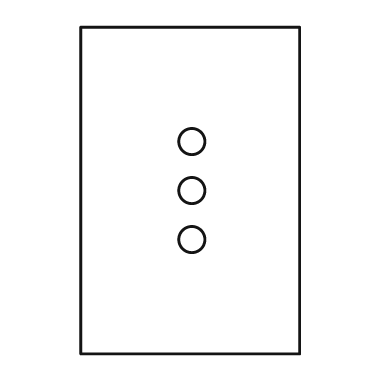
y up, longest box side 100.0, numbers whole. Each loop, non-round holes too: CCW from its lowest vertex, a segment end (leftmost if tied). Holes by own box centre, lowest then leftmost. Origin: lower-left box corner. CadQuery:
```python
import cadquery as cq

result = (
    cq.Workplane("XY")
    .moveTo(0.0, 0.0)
    .lineTo(67.0, 0.0)
    .lineTo(67.0, 100.0)
    .lineTo(0.0, 100.0)
    .close()
    .moveTo(34.0, 35.0)
    .circle(4.0)
    .moveTo(34.0, 50.0)
    .circle(4.0)
    .moveTo(34.0, 65.0)
    .circle(4.0)
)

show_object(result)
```